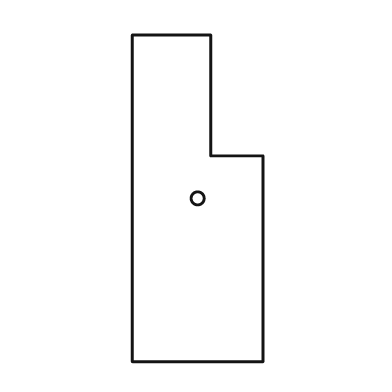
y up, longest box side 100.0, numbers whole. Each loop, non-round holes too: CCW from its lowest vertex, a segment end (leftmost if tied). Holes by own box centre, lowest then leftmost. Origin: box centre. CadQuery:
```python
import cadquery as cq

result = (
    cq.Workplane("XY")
    .moveTo(-20.0, -50.0)
    .lineTo(20.0, -50.0)
    .lineTo(20.0, 13.0)
    .lineTo(4.0, 13.0)
    .lineTo(4.0, 50.0)
    .lineTo(-20.0, 50.0)
    .close()
    .moveTo(0.0, 0.0)
    .circle(2.0)
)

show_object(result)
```